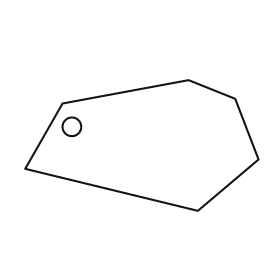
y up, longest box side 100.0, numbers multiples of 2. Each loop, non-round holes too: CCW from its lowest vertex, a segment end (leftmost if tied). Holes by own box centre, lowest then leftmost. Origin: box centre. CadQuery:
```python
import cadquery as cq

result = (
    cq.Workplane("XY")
    .moveTo(24.0, -28.0)
    .lineTo(50.0, -6.0)
    .lineTo(40.0, 20.0)
    .lineTo(20.0, 28.0)
    .lineTo(-34.0, 18.0)
    .lineTo(-50.0, -10.0)
    .close()
    .moveTo(-30.0, 8.0)
    .circle(4.0)
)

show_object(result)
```